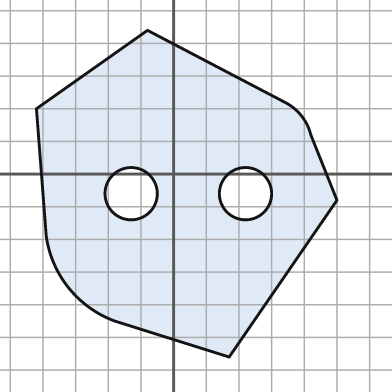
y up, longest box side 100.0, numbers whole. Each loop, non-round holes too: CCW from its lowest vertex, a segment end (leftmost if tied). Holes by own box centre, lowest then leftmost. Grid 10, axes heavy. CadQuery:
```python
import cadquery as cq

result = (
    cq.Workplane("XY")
    .moveTo(17.0, -56.0)
    .lineTo(50.0, -8.0)
    .lineTo(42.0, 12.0)
    .threePointArc((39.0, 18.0), (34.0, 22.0))
    .lineTo(-8.0, 44.0)
    .lineTo(-42.0, 20.0)
    .lineTo(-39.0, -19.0)
    .threePointArc((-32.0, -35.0), (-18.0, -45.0))
    .close()
    .moveTo(-13.0, -6.0)
    .circle(8.0)
    .moveTo(22.0, -6.0)
    .circle(8.0)
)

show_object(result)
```